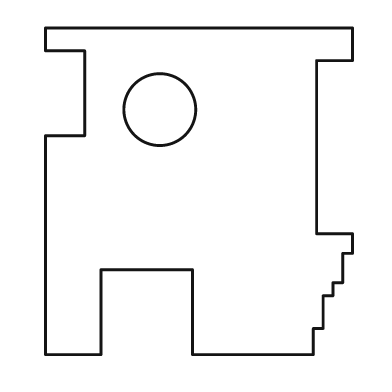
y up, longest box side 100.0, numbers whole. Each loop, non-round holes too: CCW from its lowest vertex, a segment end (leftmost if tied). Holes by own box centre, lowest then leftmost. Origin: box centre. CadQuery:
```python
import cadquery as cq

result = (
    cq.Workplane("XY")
    .moveTo(-47.0, -50.0)
    .lineTo(-30.0, -50.0)
    .lineTo(-30.0, -24.0)
    .lineTo(-2.0, -24.0)
    .lineTo(-2.0, -50.0)
    .lineTo(35.0, -50.0)
    .lineTo(35.0, -42.0)
    .lineTo(38.0, -42.0)
    .lineTo(38.0, -32.0)
    .lineTo(41.0, -32.0)
    .lineTo(41.0, -28.0)
    .lineTo(44.0, -28.0)
    .lineTo(44.0, -19.0)
    .lineTo(47.0, -19.0)
    .lineTo(47.0, -13.0)
    .lineTo(36.0, -13.0)
    .lineTo(36.0, 40.0)
    .lineTo(47.0, 40.0)
    .lineTo(47.0, 50.0)
    .lineTo(-47.0, 50.0)
    .lineTo(-47.0, 43.0)
    .lineTo(-35.0, 43.0)
    .lineTo(-35.0, 17.0)
    .lineTo(-47.0, 17.0)
    .close()
    .moveTo(-12.0, 25.0)
    .circle(11.0)
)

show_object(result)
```